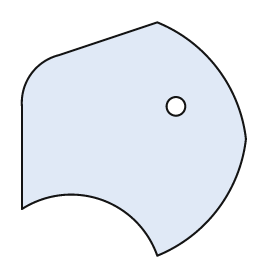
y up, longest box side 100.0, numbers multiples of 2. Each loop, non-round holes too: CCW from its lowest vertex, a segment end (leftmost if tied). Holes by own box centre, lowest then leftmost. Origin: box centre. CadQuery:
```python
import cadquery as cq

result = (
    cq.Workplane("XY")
    .moveTo(10.0, -50.0)
    .threePointArc((36.0, -30.0), (48.0, 0.0))
    .threePointArc((36.0, 30.0), (10.0, 50.0))
    .lineTo(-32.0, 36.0)
    .threePointArc((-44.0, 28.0), (-48.0, 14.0))
    .lineTo(-48.0, -30.0)
    .threePointArc((-14.0, -26.0), (10.0, -50.0))
    .close()
    .moveTo(18.0, 14.0)
    .circle(4.0)
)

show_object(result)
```